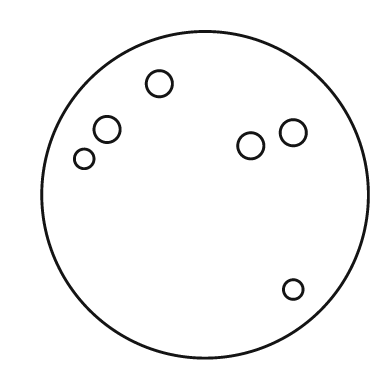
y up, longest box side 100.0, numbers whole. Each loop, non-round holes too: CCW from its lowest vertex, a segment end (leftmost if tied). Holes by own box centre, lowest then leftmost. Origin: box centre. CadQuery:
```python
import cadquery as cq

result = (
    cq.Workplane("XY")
    .moveTo(0.0, 0.0)
    .circle(50.0)
    .moveTo(27.0, -29.0)
    .circle(3.0)
    .moveTo(-37.0, 11.0)
    .circle(3.0)
    .moveTo(14.0, 15.0)
    .circle(4.0)
    .moveTo(27.0, 19.0)
    .circle(4.0)
    .moveTo(-30.0, 20.0)
    .circle(4.0)
    .moveTo(-14.0, 34.0)
    .circle(4.0)
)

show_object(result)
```